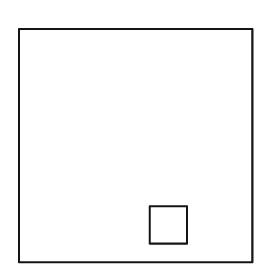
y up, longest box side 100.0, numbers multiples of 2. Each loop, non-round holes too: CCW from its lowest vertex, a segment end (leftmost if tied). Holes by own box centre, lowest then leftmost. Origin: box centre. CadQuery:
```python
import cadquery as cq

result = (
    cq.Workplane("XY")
    .moveTo(-50.0, -50.0)
    .lineTo(50.0, -50.0)
    .lineTo(50.0, 50.0)
    .lineTo(-50.0, 50.0)
    .close()
    .moveTo(6.0, -42.0)
    .lineTo(22.0, -42.0)
    .lineTo(22.0, -26.0)
    .lineTo(6.0, -26.0)
    .close()
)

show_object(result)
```